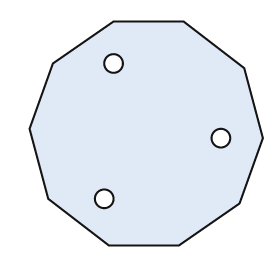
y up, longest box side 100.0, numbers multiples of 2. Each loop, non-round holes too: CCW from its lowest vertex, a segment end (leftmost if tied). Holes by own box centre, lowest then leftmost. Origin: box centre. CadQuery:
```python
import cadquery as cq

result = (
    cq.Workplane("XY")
    .moveTo(-16.0, -48.0)
    .lineTo(14.0, -48.0)
    .lineTo(40.0, -30.0)
    .lineTo(50.0, -2.0)
    .lineTo(42.0, 28.0)
    .lineTo(16.0, 48.0)
    .lineTo(-14.0, 48.0)
    .lineTo(-40.0, 30.0)
    .lineTo(-50.0, 2.0)
    .lineTo(-42.0, -28.0)
    .close()
    .moveTo(-18.0, -28.0)
    .circle(4.0)
    .moveTo(32.0, -2.0)
    .circle(4.0)
    .moveTo(-14.0, 30.0)
    .circle(4.0)
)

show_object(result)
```